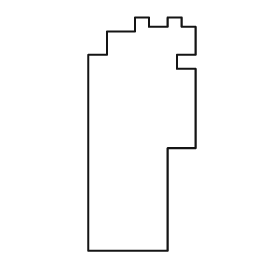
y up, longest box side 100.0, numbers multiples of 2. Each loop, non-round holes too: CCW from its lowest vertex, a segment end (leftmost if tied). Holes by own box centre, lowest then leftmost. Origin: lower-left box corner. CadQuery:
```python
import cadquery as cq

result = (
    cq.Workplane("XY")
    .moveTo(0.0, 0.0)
    .lineTo(34.0, 0.0)
    .lineTo(34.0, 44.0)
    .lineTo(46.0, 44.0)
    .lineTo(46.0, 78.0)
    .lineTo(38.0, 78.0)
    .lineTo(38.0, 84.0)
    .lineTo(46.0, 84.0)
    .lineTo(46.0, 96.0)
    .lineTo(40.0, 96.0)
    .lineTo(40.0, 100.0)
    .lineTo(34.0, 100.0)
    .lineTo(34.0, 96.0)
    .lineTo(26.0, 96.0)
    .lineTo(26.0, 100.0)
    .lineTo(20.0, 100.0)
    .lineTo(20.0, 94.0)
    .lineTo(8.0, 94.0)
    .lineTo(8.0, 84.0)
    .lineTo(0.0, 84.0)
    .close()
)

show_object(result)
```